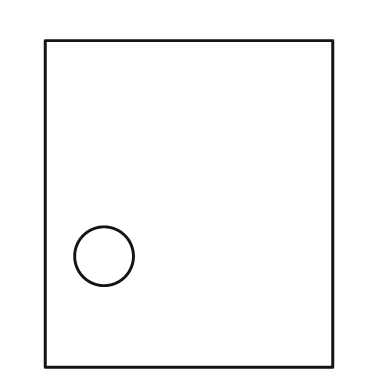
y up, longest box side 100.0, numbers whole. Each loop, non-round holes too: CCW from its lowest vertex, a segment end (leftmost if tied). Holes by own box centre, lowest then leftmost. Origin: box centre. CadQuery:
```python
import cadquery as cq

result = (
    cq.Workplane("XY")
    .moveTo(-44.0, -50.0)
    .lineTo(44.0, -50.0)
    .lineTo(44.0, 50.0)
    .lineTo(-44.0, 50.0)
    .close()
    .moveTo(-26.0, -16.0)
    .circle(9.0)
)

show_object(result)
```